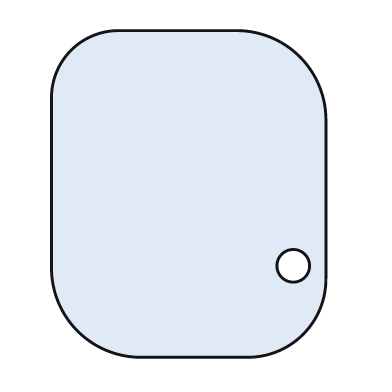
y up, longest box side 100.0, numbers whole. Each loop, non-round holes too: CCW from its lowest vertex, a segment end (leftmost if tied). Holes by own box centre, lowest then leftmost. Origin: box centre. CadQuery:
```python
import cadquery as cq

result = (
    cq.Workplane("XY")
    .moveTo(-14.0, -50.0)
    .lineTo(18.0, -50.0)
    .threePointArc((35.0, -43.0), (42.0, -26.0))
    .lineTo(42.0, 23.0)
    .threePointArc((34.0, 42.0), (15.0, 50.0))
    .lineTo(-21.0, 50.0)
    .threePointArc((-36.0, 44.0), (-42.0, 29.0))
    .lineTo(-42.0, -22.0)
    .threePointArc((-34.0, -42.0), (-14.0, -50.0))
    .close()
    .moveTo(32.0, -22.0)
    .circle(5.0)
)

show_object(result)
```